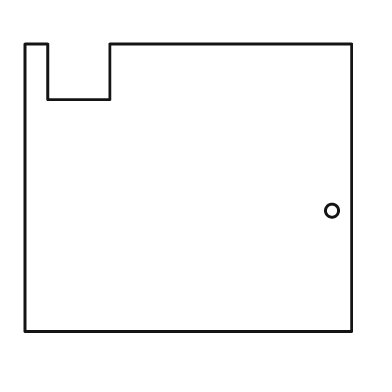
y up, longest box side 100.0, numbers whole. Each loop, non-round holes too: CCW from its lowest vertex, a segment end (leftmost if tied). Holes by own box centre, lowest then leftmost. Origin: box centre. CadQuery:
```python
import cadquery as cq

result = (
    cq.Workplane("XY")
    .moveTo(-50.0, -44.0)
    .lineTo(50.0, -44.0)
    .lineTo(50.0, 44.0)
    .lineTo(-24.0, 44.0)
    .lineTo(-24.0, 27.0)
    .lineTo(-43.0, 27.0)
    .lineTo(-43.0, 44.0)
    .lineTo(-50.0, 44.0)
    .close()
    .moveTo(44.0, -7.0)
    .circle(2.0)
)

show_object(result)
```